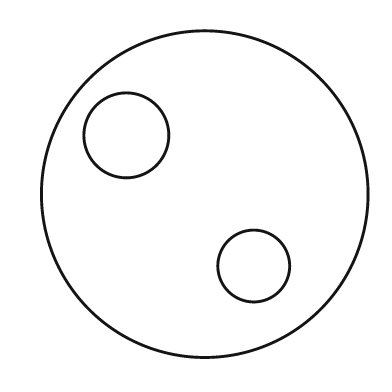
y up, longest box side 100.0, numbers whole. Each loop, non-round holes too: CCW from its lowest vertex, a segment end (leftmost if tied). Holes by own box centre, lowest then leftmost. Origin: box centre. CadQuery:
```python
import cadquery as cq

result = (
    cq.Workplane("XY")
    .moveTo(0.0, 0.0)
    .circle(50.0)
    .moveTo(15.0, -22.0)
    .circle(11.0)
    .moveTo(-24.0, 18.0)
    .circle(13.0)
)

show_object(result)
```